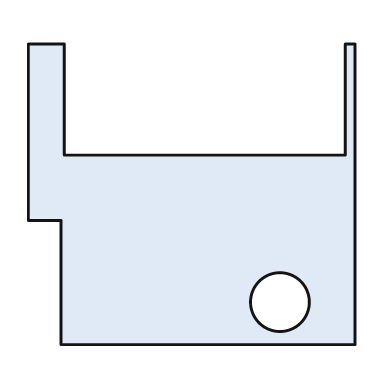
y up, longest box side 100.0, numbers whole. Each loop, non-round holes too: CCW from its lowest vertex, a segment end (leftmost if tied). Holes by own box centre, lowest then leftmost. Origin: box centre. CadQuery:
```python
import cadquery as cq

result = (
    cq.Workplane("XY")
    .moveTo(-40.0, -46.0)
    .lineTo(50.0, -46.0)
    .lineTo(50.0, 46.0)
    .lineTo(47.0, 46.0)
    .lineTo(47.0, 12.0)
    .lineTo(-39.0, 12.0)
    .lineTo(-39.0, 46.0)
    .lineTo(-50.0, 46.0)
    .lineTo(-50.0, -8.0)
    .lineTo(-40.0, -8.0)
    .close()
    .moveTo(27.0, -33.0)
    .circle(9.0)
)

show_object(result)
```